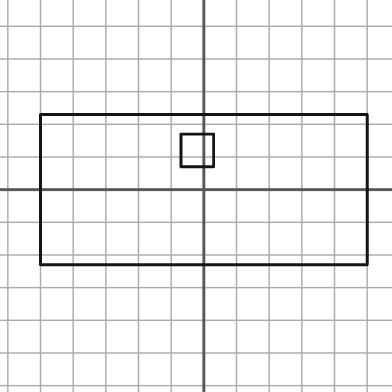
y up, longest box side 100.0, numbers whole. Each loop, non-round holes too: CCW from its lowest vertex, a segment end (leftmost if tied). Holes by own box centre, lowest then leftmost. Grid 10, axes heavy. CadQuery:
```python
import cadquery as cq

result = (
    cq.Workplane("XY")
    .moveTo(-50.0, -23.0)
    .lineTo(50.0, -23.0)
    .lineTo(50.0, 23.0)
    .lineTo(-50.0, 23.0)
    .close()
    .moveTo(-7.0, 7.0)
    .lineTo(3.0, 7.0)
    .lineTo(3.0, 17.0)
    .lineTo(-7.0, 17.0)
    .close()
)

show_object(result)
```